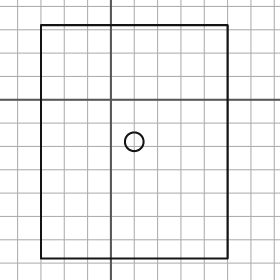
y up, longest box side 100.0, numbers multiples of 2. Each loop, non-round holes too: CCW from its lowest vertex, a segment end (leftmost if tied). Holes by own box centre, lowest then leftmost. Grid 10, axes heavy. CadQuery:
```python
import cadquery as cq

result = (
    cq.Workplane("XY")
    .moveTo(-30.0, -68.0)
    .lineTo(50.0, -68.0)
    .lineTo(50.0, 32.0)
    .lineTo(-30.0, 32.0)
    .close()
    .moveTo(10.0, -18.0)
    .circle(4.0)
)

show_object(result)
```